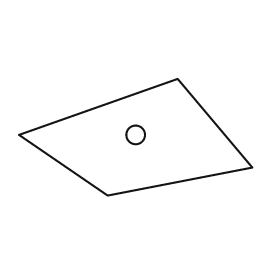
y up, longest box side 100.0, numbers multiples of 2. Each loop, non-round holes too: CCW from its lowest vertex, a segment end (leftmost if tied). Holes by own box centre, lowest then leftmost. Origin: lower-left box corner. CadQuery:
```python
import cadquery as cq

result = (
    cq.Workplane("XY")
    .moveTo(38.0, 0.0)
    .lineTo(100.0, 12.0)
    .lineTo(68.0, 50.0)
    .lineTo(0.0, 26.0)
    .close()
    .moveTo(50.0, 26.0)
    .circle(4.0)
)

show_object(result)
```